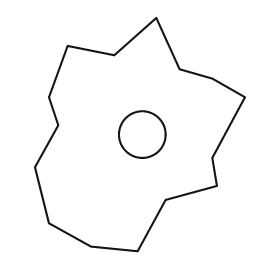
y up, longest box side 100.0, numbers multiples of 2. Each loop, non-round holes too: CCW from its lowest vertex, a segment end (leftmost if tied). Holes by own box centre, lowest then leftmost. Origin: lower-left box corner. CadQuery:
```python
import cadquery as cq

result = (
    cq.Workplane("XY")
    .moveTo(44.0, 0.0)
    .lineTo(56.0, 22.0)
    .lineTo(78.0, 28.0)
    .lineTo(76.0, 40.0)
    .lineTo(90.0, 66.0)
    .lineTo(76.0, 74.0)
    .lineTo(62.0, 78.0)
    .lineTo(52.0, 100.0)
    .lineTo(34.0, 84.0)
    .lineTo(14.0, 88.0)
    .lineTo(6.0, 66.0)
    .lineTo(10.0, 54.0)
    .lineTo(0.0, 36.0)
    .lineTo(6.0, 12.0)
    .lineTo(24.0, 2.0)
    .close()
    .moveTo(46.0, 50.0)
    .circle(10.0)
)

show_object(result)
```